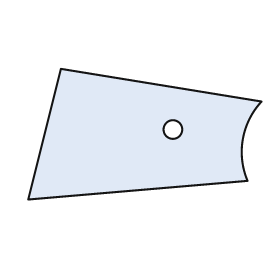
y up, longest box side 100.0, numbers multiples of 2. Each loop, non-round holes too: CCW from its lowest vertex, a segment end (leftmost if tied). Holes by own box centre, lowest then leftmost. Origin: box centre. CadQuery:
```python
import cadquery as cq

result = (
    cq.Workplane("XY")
    .moveTo(-50.0, -28.0)
    .lineTo(44.0, -20.0)
    .threePointArc((42.0, -2.0), (50.0, 14.0))
    .lineTo(-36.0, 28.0)
    .close()
    .moveTo(12.0, 2.0)
    .circle(4.0)
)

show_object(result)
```